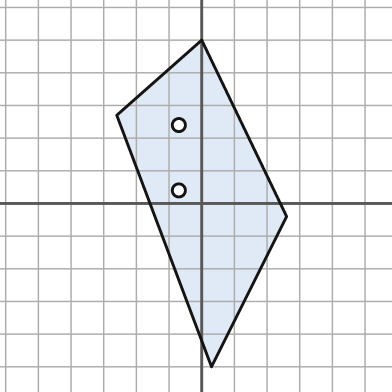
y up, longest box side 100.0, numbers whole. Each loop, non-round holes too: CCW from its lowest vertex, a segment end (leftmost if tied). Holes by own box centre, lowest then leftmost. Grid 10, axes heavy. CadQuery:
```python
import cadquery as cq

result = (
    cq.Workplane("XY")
    .moveTo(3.0, -50.0)
    .lineTo(26.0, -4.0)
    .lineTo(0.0, 50.0)
    .lineTo(-26.0, 27.0)
    .close()
    .moveTo(-7.0, 4.0)
    .circle(2.0)
    .moveTo(-7.0, 24.0)
    .circle(2.0)
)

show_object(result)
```